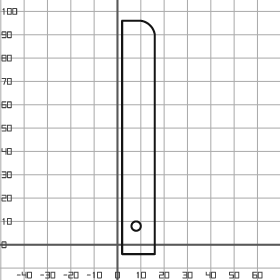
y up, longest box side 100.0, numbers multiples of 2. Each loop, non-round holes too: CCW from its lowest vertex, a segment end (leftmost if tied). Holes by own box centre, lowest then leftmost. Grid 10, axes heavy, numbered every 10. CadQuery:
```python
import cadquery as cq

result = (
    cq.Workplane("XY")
    .moveTo(2.0, -4.0)
    .lineTo(16.0, -4.0)
    .lineTo(16.0, 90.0)
    .threePointArc((14.0, 94.0), (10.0, 96.0))
    .lineTo(2.0, 96.0)
    .close()
    .moveTo(8.0, 8.0)
    .circle(2.0)
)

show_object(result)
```